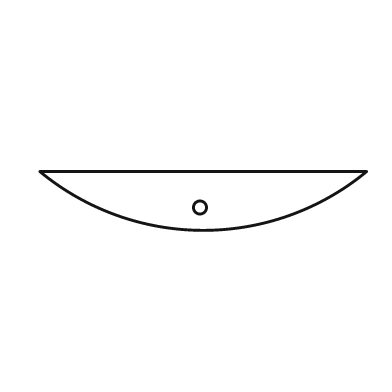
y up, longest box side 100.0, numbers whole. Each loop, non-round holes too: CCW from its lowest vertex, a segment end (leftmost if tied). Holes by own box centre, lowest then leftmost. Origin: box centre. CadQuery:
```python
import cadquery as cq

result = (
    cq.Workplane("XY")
    .moveTo(-50.0, 9.0)
    .threePointArc((0.0, -9.0), (50.0, 9.0))
    .close()
    .moveTo(-1.0, -2.0)
    .circle(2.0)
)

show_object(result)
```